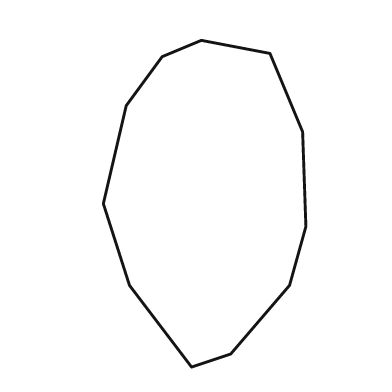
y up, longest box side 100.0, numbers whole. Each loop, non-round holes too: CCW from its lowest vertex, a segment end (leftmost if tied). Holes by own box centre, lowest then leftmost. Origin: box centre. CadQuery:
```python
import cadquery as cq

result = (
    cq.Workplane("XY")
    .moveTo(-4.0, -50.0)
    .lineTo(8.0, -46.0)
    .lineTo(26.0, -25.0)
    .lineTo(31.0, -7.0)
    .lineTo(30.0, 22.0)
    .lineTo(20.0, 46.0)
    .lineTo(-1.0, 50.0)
    .lineTo(-13.0, 45.0)
    .lineTo(-24.0, 30.0)
    .lineTo(-31.0, 0.0)
    .lineTo(-23.0, -25.0)
    .close()
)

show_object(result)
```